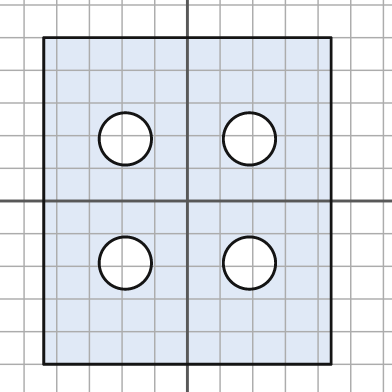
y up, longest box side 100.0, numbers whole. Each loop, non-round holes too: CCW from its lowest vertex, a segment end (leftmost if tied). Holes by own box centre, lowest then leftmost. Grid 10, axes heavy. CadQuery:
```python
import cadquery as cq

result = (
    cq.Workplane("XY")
    .moveTo(-44.0, -50.0)
    .lineTo(44.0, -50.0)
    .lineTo(44.0, 50.0)
    .lineTo(-44.0, 50.0)
    .close()
    .moveTo(-19.0, -19.0)
    .circle(8.0)
    .moveTo(19.0, -19.0)
    .circle(8.0)
    .moveTo(-19.0, 19.0)
    .circle(8.0)
    .moveTo(19.0, 19.0)
    .circle(8.0)
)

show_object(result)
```